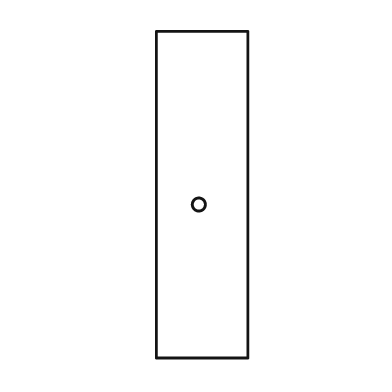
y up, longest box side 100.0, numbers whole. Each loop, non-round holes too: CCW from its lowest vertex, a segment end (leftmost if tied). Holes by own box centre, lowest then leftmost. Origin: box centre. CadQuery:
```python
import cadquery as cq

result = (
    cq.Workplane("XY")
    .moveTo(-14.0, -50.0)
    .lineTo(14.0, -50.0)
    .lineTo(14.0, 50.0)
    .lineTo(-14.0, 50.0)
    .close()
    .moveTo(-1.0, -3.0)
    .circle(2.0)
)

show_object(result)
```